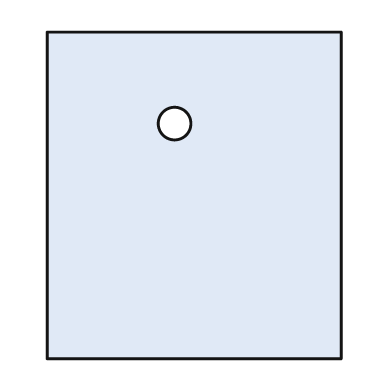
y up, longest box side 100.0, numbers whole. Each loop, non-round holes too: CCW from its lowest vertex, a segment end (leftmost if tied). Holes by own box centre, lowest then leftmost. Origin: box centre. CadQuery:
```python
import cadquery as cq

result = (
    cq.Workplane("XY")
    .moveTo(-45.0, -50.0)
    .lineTo(45.0, -50.0)
    .lineTo(45.0, 50.0)
    .lineTo(-45.0, 50.0)
    .close()
    .moveTo(-6.0, 22.0)
    .circle(5.0)
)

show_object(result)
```